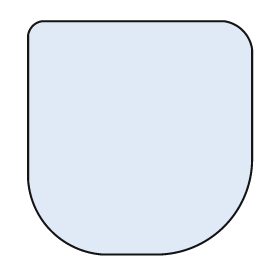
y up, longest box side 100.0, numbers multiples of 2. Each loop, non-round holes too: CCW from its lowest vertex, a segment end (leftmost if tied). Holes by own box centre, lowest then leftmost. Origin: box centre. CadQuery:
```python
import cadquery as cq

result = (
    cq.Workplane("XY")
    .moveTo(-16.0, -50.0)
    .lineTo(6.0, -50.0)
    .threePointArc((36.0, -38.0), (48.0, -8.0))
    .lineTo(48.0, 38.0)
    .threePointArc((44.0, 46.0), (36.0, 50.0))
    .lineTo(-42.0, 50.0)
    .threePointArc((-46.0, 48.0), (-48.0, 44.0))
    .lineTo(-48.0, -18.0)
    .threePointArc((-38.0, -40.0), (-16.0, -50.0))
    .close()
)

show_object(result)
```